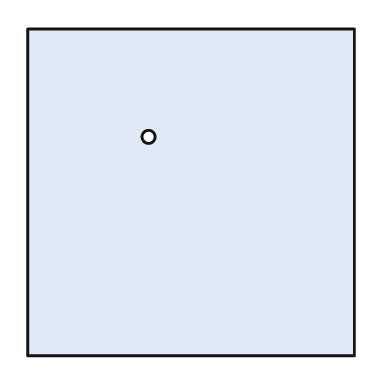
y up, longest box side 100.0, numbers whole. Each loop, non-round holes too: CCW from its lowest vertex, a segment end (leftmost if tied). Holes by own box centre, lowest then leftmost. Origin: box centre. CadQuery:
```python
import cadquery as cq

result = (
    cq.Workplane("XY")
    .moveTo(-50.0, -50.0)
    .lineTo(50.0, -50.0)
    .lineTo(50.0, 50.0)
    .lineTo(-50.0, 50.0)
    .close()
    .moveTo(-13.0, 17.0)
    .circle(2.0)
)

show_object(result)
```